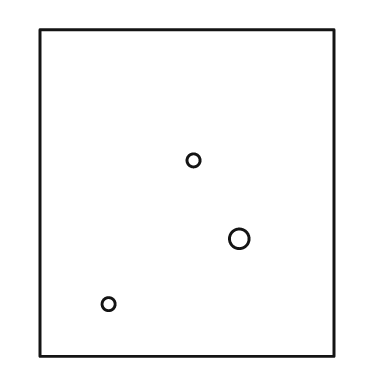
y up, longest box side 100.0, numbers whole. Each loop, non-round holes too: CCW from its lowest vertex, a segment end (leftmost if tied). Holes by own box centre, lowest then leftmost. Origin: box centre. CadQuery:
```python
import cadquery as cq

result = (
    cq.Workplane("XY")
    .moveTo(-45.0, -50.0)
    .lineTo(45.0, -50.0)
    .lineTo(45.0, 50.0)
    .lineTo(-45.0, 50.0)
    .close()
    .moveTo(-24.0, -34.0)
    .circle(2.0)
    .moveTo(16.0, -14.0)
    .circle(3.0)
    .moveTo(2.0, 10.0)
    .circle(2.0)
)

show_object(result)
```